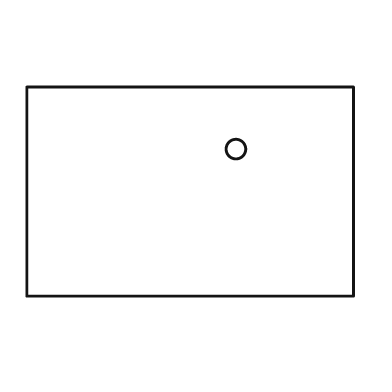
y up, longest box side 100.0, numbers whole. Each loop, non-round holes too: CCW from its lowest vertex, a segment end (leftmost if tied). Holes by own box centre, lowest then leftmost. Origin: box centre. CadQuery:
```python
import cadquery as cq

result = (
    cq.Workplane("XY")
    .moveTo(-50.0, -32.0)
    .lineTo(50.0, -32.0)
    .lineTo(50.0, 32.0)
    .lineTo(-50.0, 32.0)
    .close()
    .moveTo(14.0, 13.0)
    .circle(3.0)
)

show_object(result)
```